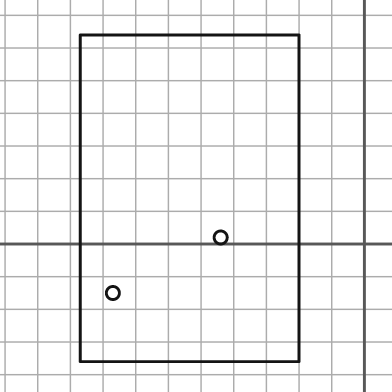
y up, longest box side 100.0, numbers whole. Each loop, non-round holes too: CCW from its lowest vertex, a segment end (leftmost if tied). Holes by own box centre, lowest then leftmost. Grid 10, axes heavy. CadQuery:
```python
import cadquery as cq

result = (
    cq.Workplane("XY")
    .moveTo(-87.0, -36.0)
    .lineTo(-20.0, -36.0)
    .lineTo(-20.0, 64.0)
    .lineTo(-87.0, 64.0)
    .close()
    .moveTo(-77.0, -15.0)
    .circle(2.0)
    .moveTo(-44.0, 2.0)
    .circle(2.0)
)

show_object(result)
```